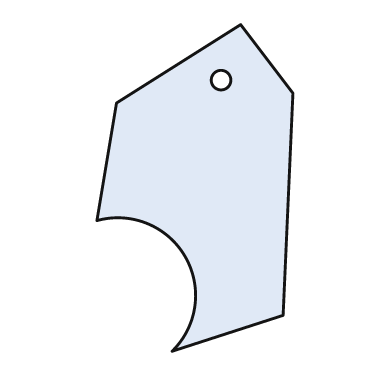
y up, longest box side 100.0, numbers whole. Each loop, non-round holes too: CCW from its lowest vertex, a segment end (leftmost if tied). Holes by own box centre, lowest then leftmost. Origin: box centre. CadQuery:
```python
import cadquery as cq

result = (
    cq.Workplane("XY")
    .moveTo(-7.0, -50.0)
    .lineTo(27.0, -39.0)
    .lineTo(30.0, 29.0)
    .lineTo(14.0, 50.0)
    .lineTo(-24.0, 26.0)
    .lineTo(-30.0, -10.0)
    .threePointArc((-3.0, -21.0), (-7.0, -50.0))
    .close()
    .moveTo(8.0, 33.0)
    .circle(3.0)
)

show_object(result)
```